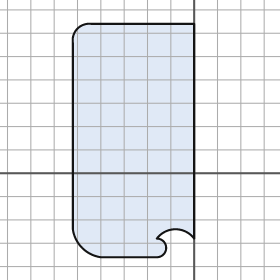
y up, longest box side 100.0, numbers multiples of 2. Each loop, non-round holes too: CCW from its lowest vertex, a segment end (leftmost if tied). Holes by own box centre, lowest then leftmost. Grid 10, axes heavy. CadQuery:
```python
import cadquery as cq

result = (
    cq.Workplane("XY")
    .moveTo(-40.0, -36.0)
    .lineTo(-16.0, -36.0)
    .threePointArc((-12.0, -32.0), (-16.0, -28.0))
    .threePointArc((-8.0, -24.0), (0.0, -28.0))
    .lineTo(0.0, 64.0)
    .lineTo(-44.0, 64.0)
    .threePointArc((-50.0, 62.0), (-52.0, 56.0))
    .lineTo(-52.0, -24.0)
    .threePointArc((-48.0, -32.0), (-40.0, -36.0))
    .close()
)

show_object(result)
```